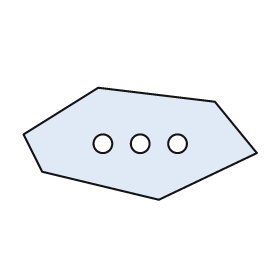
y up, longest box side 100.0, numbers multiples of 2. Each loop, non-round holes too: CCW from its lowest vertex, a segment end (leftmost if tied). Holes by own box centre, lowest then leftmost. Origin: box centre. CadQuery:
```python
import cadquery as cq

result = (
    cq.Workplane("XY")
    .moveTo(8.0, -24.0)
    .lineTo(50.0, -4.0)
    .lineTo(32.0, 18.0)
    .lineTo(-18.0, 24.0)
    .lineTo(-50.0, 4.0)
    .lineTo(-42.0, -12.0)
    .close()
    .moveTo(-16.0, 0.0)
    .circle(4.0)
    .moveTo(0.0, 0.0)
    .circle(4.0)
    .moveTo(16.0, 0.0)
    .circle(4.0)
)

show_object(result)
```